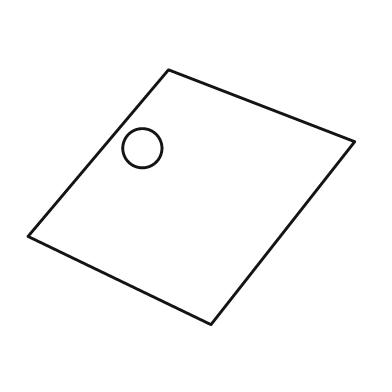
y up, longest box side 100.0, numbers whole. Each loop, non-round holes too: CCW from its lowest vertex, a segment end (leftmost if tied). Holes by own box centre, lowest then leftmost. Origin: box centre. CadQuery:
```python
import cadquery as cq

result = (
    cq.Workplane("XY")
    .moveTo(6.0, -39.0)
    .lineTo(50.0, 17.0)
    .lineTo(-7.0, 39.0)
    .lineTo(-50.0, -12.0)
    .close()
    .moveTo(-15.0, 15.0)
    .circle(6.0)
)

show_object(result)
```